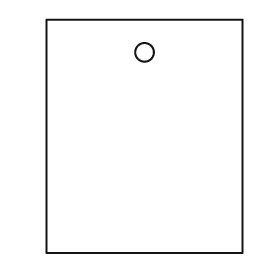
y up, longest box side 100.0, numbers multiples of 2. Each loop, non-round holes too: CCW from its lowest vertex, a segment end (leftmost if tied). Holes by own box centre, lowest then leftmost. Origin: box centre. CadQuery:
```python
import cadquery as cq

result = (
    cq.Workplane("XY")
    .moveTo(-42.0, -50.0)
    .lineTo(42.0, -50.0)
    .lineTo(42.0, 50.0)
    .lineTo(-42.0, 50.0)
    .close()
    .moveTo(0.0, 36.0)
    .circle(4.0)
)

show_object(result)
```